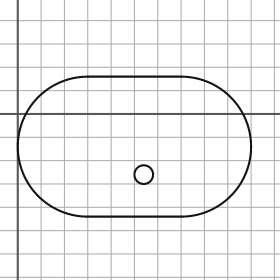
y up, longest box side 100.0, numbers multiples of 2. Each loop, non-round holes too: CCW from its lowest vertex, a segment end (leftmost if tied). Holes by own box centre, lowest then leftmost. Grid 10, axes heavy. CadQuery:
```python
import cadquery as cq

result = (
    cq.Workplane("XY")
    .moveTo(30.0, -44.0)
    .lineTo(70.0, -44.0)
    .threePointArc((100.0, -14.0), (70.0, 16.0))
    .lineTo(30.0, 16.0)
    .threePointArc((0.0, -14.0), (30.0, -44.0))
    .close()
    .moveTo(54.0, -26.0)
    .circle(4.0)
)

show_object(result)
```